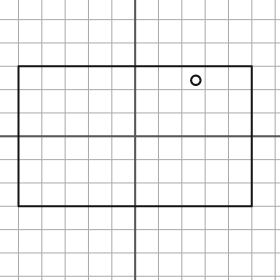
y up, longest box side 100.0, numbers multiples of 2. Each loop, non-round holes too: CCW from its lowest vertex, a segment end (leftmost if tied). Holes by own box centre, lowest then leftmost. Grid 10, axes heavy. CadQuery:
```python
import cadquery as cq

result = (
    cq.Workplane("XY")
    .moveTo(-50.0, -30.0)
    .lineTo(50.0, -30.0)
    .lineTo(50.0, 30.0)
    .lineTo(-50.0, 30.0)
    .close()
    .moveTo(26.0, 24.0)
    .circle(2.0)
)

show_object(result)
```